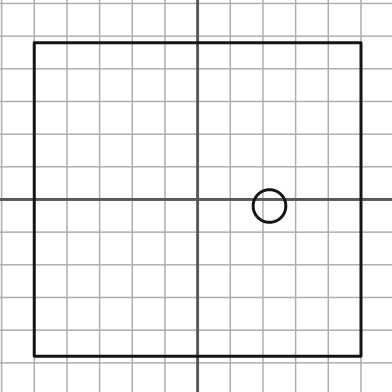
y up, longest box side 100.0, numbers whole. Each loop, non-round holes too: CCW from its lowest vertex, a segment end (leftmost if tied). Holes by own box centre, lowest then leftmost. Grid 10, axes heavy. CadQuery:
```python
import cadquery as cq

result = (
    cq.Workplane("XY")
    .moveTo(-50.0, -48.0)
    .lineTo(50.0, -48.0)
    .lineTo(50.0, 48.0)
    .lineTo(-50.0, 48.0)
    .close()
    .moveTo(22.0, -2.0)
    .circle(5.0)
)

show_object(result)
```